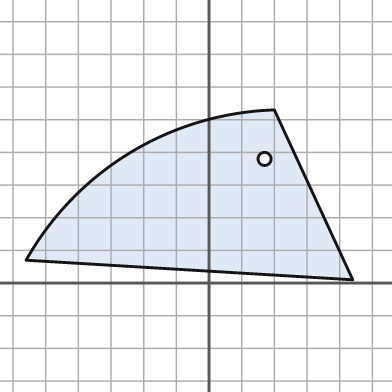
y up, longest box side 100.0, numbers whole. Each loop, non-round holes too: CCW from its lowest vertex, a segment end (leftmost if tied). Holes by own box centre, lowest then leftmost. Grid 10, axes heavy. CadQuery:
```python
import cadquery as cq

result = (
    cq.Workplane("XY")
    .moveTo(44.0, 1.0)
    .lineTo(20.0, 53.0)
    .threePointArc((-24.0, 40.0), (-56.0, 7.0))
    .close()
    .moveTo(17.0, 38.0)
    .circle(2.0)
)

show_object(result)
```